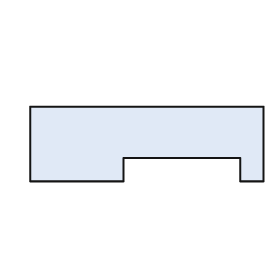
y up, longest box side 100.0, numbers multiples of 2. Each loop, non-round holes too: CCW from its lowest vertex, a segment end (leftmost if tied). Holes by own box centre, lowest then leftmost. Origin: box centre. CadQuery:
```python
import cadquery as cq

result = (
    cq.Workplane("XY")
    .moveTo(-50.0, -16.0)
    .lineTo(-10.0, -16.0)
    .lineTo(-10.0, -6.0)
    .lineTo(40.0, -6.0)
    .lineTo(40.0, -16.0)
    .lineTo(50.0, -16.0)
    .lineTo(50.0, 16.0)
    .lineTo(-50.0, 16.0)
    .close()
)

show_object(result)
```